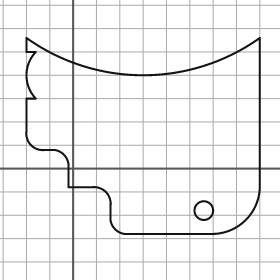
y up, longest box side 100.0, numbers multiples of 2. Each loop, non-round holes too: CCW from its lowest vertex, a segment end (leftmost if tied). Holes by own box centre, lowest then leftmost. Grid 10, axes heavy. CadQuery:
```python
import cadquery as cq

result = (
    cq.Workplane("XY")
    .moveTo(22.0, -28.0)
    .lineTo(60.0, -28.0)
    .threePointArc((74.0, -22.0), (80.0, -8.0))
    .lineTo(80.0, 56.0)
    .threePointArc((30.0, 40.0), (-20.0, 56.0))
    .lineTo(-20.0, 50.0)
    .lineTo(-16.0, 50.0)
    .threePointArc((-20.0, 40.0), (-16.0, 30.0))
    .lineTo(-20.0, 30.0)
    .lineTo(-20.0, 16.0)
    .threePointArc((-18.0, 10.0), (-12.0, 8.0))
    .lineTo(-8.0, 8.0)
    .threePointArc((-4.0, 6.0), (-2.0, 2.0))
    .lineTo(-2.0, -8.0)
    .lineTo(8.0, -8.0)
    .threePointArc((14.0, -10.0), (16.0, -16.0))
    .lineTo(16.0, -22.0)
    .threePointArc((18.0, -26.0), (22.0, -28.0))
    .close()
    .moveTo(56.0, -18.0)
    .circle(4.0)
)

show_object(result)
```